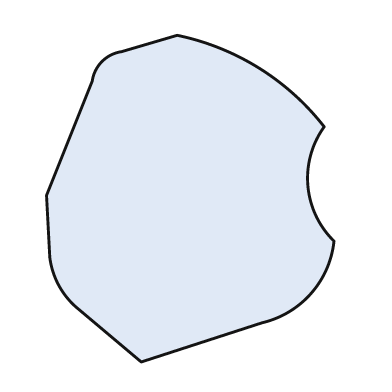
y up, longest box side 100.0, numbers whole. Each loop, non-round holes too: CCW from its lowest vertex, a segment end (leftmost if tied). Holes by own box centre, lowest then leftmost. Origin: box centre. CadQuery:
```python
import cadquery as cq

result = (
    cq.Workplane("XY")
    .moveTo(-15.0, -50.0)
    .lineTo(22.0, -38.0)
    .threePointArc((37.0, -29.0), (44.0, -13.0))
    .threePointArc((36.0, 4.0), (41.0, 22.0))
    .threePointArc((21.0, 40.0), (-4.0, 50.0))
    .lineTo(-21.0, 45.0)
    .threePointArc((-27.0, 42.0), (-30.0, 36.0))
    .lineTo(-44.0, 1.0)
    .lineTo(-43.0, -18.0)
    .threePointArc((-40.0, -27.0), (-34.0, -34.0))
    .close()
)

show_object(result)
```